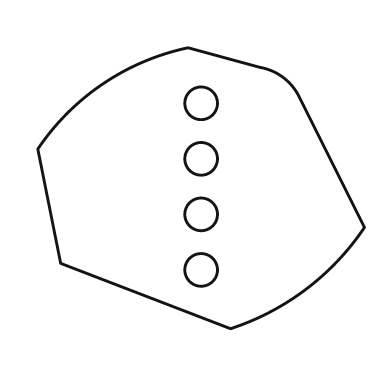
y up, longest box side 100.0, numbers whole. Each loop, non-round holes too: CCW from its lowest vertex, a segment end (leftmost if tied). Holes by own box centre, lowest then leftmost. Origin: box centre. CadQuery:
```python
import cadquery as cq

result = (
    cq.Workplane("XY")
    .moveTo(9.0, -43.0)
    .threePointArc((32.0, -31.0), (50.0, -12.0))
    .lineTo(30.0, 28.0)
    .threePointArc((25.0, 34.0), (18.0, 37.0))
    .lineTo(-4.0, 43.0)
    .threePointArc((-30.0, 32.0), (-50.0, 12.0))
    .lineTo(-43.0, -23.0)
    .close()
    .moveTo(0.0, -25.0)
    .circle(5.0)
    .moveTo(0.0, -8.0)
    .circle(5.0)
    .moveTo(0.0, 9.0)
    .circle(5.0)
    .moveTo(0.0, 26.0)
    .circle(5.0)
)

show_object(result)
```